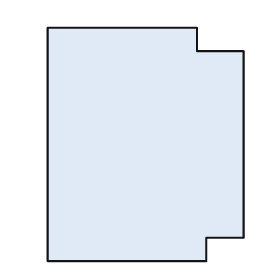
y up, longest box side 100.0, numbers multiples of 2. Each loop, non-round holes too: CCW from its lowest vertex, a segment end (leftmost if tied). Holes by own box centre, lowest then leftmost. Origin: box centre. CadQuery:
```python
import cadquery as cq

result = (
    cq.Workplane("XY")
    .moveTo(-42.0, -50.0)
    .lineTo(26.0, -50.0)
    .lineTo(26.0, -40.0)
    .lineTo(42.0, -40.0)
    .lineTo(42.0, 40.0)
    .lineTo(22.0, 40.0)
    .lineTo(22.0, 50.0)
    .lineTo(-42.0, 50.0)
    .close()
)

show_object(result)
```